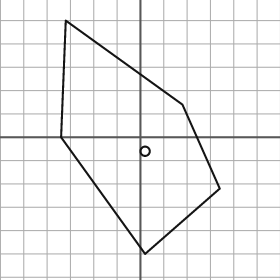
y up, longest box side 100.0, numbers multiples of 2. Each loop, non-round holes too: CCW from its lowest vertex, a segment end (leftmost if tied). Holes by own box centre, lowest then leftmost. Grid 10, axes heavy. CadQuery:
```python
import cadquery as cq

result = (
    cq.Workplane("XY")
    .moveTo(2.0, -50.0)
    .lineTo(34.0, -22.0)
    .lineTo(18.0, 14.0)
    .lineTo(-32.0, 50.0)
    .lineTo(-34.0, 0.0)
    .close()
    .moveTo(2.0, -6.0)
    .circle(2.0)
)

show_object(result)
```